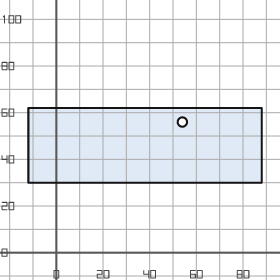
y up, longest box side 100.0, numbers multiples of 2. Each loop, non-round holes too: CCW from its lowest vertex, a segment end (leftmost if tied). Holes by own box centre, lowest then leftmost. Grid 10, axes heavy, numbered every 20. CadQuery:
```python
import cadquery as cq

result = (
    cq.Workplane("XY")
    .moveTo(-12.0, 30.0)
    .lineTo(88.0, 30.0)
    .lineTo(88.0, 62.0)
    .lineTo(-12.0, 62.0)
    .close()
    .moveTo(54.0, 56.0)
    .circle(2.0)
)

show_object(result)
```